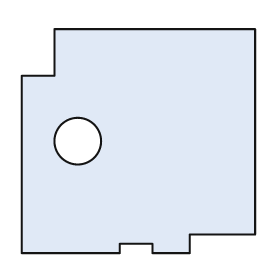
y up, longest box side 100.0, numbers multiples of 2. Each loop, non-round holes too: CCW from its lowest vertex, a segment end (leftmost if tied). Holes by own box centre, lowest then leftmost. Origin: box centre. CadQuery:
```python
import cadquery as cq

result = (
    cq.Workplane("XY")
    .moveTo(-50.0, -48.0)
    .lineTo(-8.0, -48.0)
    .lineTo(-8.0, -44.0)
    .lineTo(6.0, -44.0)
    .lineTo(6.0, -48.0)
    .lineTo(22.0, -48.0)
    .lineTo(22.0, -40.0)
    .lineTo(50.0, -40.0)
    .lineTo(50.0, 48.0)
    .lineTo(-36.0, 48.0)
    .lineTo(-36.0, 28.0)
    .lineTo(-50.0, 28.0)
    .close()
    .moveTo(-26.0, 0.0)
    .circle(10.0)
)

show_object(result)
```